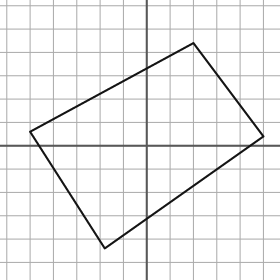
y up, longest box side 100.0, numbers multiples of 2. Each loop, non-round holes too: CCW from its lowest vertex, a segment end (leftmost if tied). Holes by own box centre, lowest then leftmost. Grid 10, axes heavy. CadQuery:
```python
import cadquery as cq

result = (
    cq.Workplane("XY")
    .moveTo(-18.0, -44.0)
    .lineTo(50.0, 4.0)
    .lineTo(20.0, 44.0)
    .lineTo(-50.0, 6.0)
    .close()
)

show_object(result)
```